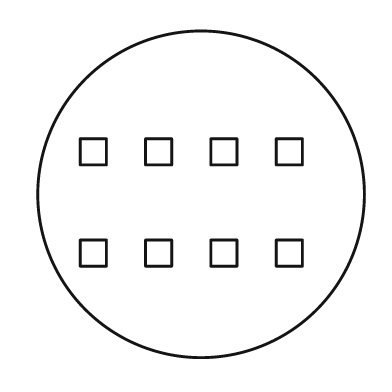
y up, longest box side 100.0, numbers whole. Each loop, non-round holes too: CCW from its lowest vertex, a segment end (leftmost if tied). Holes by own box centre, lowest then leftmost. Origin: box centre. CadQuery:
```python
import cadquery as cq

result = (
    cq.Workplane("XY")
    .moveTo(0.0, 0.0)
    .circle(50.0)
    .moveTo(-37.0, -22.0)
    .lineTo(-29.0, -22.0)
    .lineTo(-29.0, -14.0)
    .lineTo(-37.0, -14.0)
    .close()
    .moveTo(-17.0, -22.0)
    .lineTo(-9.0, -22.0)
    .lineTo(-9.0, -14.0)
    .lineTo(-17.0, -14.0)
    .close()
    .moveTo(3.0, -22.0)
    .lineTo(11.0, -22.0)
    .lineTo(11.0, -14.0)
    .lineTo(3.0, -14.0)
    .close()
    .moveTo(23.0, -22.0)
    .lineTo(31.0, -22.0)
    .lineTo(31.0, -14.0)
    .lineTo(23.0, -14.0)
    .close()
    .moveTo(-37.0, 9.0)
    .lineTo(-29.0, 9.0)
    .lineTo(-29.0, 17.0)
    .lineTo(-37.0, 17.0)
    .close()
    .moveTo(-17.0, 9.0)
    .lineTo(-9.0, 9.0)
    .lineTo(-9.0, 17.0)
    .lineTo(-17.0, 17.0)
    .close()
    .moveTo(3.0, 9.0)
    .lineTo(11.0, 9.0)
    .lineTo(11.0, 17.0)
    .lineTo(3.0, 17.0)
    .close()
    .moveTo(23.0, 9.0)
    .lineTo(31.0, 9.0)
    .lineTo(31.0, 17.0)
    .lineTo(23.0, 17.0)
    .close()
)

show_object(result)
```